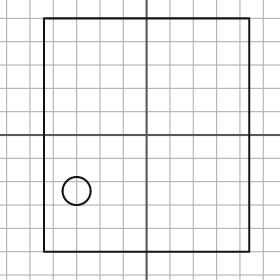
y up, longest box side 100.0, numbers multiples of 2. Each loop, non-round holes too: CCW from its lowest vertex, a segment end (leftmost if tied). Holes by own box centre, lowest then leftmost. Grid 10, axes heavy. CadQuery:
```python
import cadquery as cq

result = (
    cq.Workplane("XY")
    .moveTo(-44.0, -50.0)
    .lineTo(44.0, -50.0)
    .lineTo(44.0, 50.0)
    .lineTo(-44.0, 50.0)
    .close()
    .moveTo(-30.0, -24.0)
    .circle(6.0)
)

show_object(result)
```